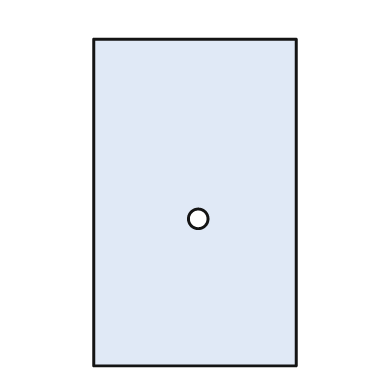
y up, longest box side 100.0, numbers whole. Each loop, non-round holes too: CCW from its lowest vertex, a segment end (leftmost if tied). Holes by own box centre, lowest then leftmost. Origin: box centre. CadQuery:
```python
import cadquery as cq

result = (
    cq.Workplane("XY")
    .moveTo(-31.0, -50.0)
    .lineTo(31.0, -50.0)
    .lineTo(31.0, 50.0)
    .lineTo(-31.0, 50.0)
    .close()
    .moveTo(1.0, -5.0)
    .circle(3.0)
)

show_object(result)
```